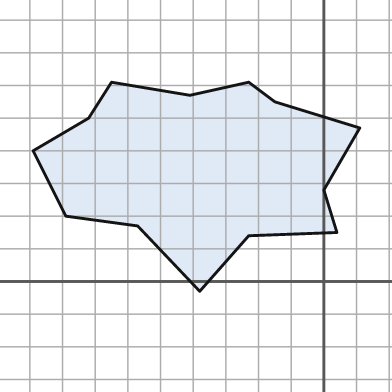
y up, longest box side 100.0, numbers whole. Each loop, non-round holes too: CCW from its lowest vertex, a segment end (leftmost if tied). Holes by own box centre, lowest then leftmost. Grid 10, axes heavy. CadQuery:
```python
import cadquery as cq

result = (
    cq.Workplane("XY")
    .moveTo(-38.0, -3.0)
    .lineTo(-23.0, 14.0)
    .lineTo(4.0, 15.0)
    .lineTo(0.0, 28.0)
    .lineTo(11.0, 47.0)
    .lineTo(-15.0, 55.0)
    .lineTo(-23.0, 61.0)
    .lineTo(-41.0, 57.0)
    .lineTo(-65.0, 61.0)
    .lineTo(-72.0, 50.0)
    .lineTo(-89.0, 40.0)
    .lineTo(-79.0, 20.0)
    .lineTo(-57.0, 17.0)
    .close()
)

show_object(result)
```